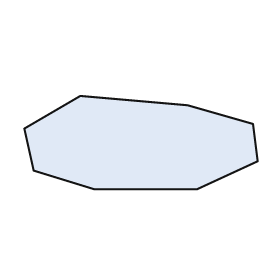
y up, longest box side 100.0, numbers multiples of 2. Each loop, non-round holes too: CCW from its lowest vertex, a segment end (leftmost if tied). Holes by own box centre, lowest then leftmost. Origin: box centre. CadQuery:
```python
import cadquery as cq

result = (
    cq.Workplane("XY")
    .moveTo(-20.0, -20.0)
    .lineTo(24.0, -20.0)
    .lineTo(50.0, -8.0)
    .lineTo(48.0, 8.0)
    .lineTo(20.0, 16.0)
    .lineTo(-26.0, 20.0)
    .lineTo(-50.0, 6.0)
    .lineTo(-46.0, -12.0)
    .close()
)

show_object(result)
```